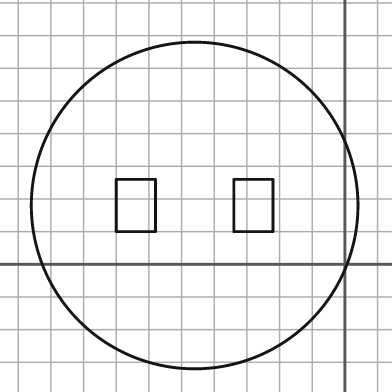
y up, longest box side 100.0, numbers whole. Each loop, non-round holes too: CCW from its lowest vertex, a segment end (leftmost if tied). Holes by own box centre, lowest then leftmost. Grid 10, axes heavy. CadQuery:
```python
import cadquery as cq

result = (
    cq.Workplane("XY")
    .moveTo(-46.0, 18.0)
    .circle(50.0)
    .moveTo(-70.0, 10.0)
    .lineTo(-58.0, 10.0)
    .lineTo(-58.0, 26.0)
    .lineTo(-70.0, 26.0)
    .close()
    .moveTo(-34.0, 10.0)
    .lineTo(-22.0, 10.0)
    .lineTo(-22.0, 26.0)
    .lineTo(-34.0, 26.0)
    .close()
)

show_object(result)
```